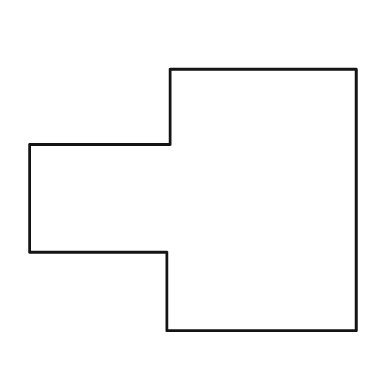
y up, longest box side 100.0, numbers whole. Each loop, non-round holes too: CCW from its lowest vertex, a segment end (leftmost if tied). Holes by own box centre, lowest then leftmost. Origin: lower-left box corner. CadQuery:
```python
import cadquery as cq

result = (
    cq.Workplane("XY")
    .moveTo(42.0, 0.0)
    .lineTo(100.0, 0.0)
    .lineTo(100.0, 80.0)
    .lineTo(43.0, 80.0)
    .lineTo(43.0, 57.0)
    .lineTo(0.0, 57.0)
    .lineTo(0.0, 24.0)
    .lineTo(42.0, 24.0)
    .close()
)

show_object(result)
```